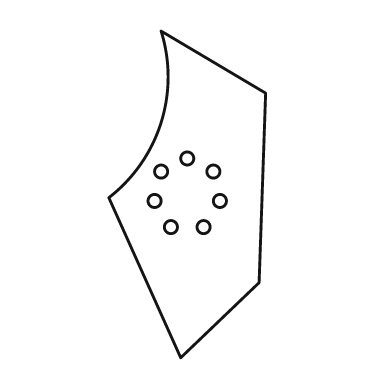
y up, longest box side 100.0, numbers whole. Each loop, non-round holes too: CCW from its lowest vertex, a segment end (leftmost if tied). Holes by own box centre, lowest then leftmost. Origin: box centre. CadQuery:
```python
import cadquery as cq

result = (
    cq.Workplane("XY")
    .moveTo(-2.0, -50.0)
    .lineTo(22.0, -27.0)
    .lineTo(24.0, 31.0)
    .lineTo(-8.0, 50.0)
    .threePointArc((-8.0, 22.0), (-24.0, -1.0))
    .close()
    .moveTo(-5.0, -10.0)
    .circle(2.0)
    .moveTo(5.0, -10.0)
    .circle(2.0)
    .moveTo(-10.0, -2.0)
    .circle(2.0)
    .moveTo(10.0, -2.0)
    .circle(2.0)
    .moveTo(-8.0, 7.0)
    .circle(2.0)
    .moveTo(8.0, 7.0)
    .circle(2.0)
    .moveTo(0.0, 11.0)
    .circle(2.0)
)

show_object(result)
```